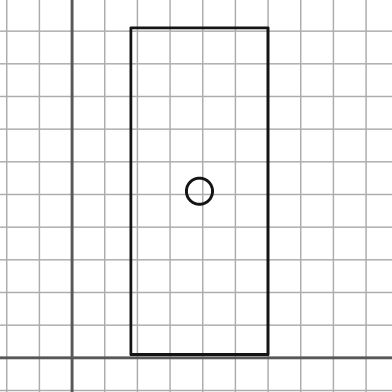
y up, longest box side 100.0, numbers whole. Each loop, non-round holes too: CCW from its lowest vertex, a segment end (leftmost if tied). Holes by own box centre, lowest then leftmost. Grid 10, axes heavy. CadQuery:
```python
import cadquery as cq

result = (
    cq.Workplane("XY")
    .moveTo(18.0, 1.0)
    .lineTo(60.0, 1.0)
    .lineTo(60.0, 101.0)
    .lineTo(18.0, 101.0)
    .close()
    .moveTo(39.0, 51.0)
    .circle(4.0)
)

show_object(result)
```